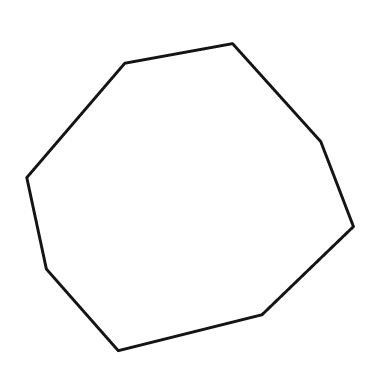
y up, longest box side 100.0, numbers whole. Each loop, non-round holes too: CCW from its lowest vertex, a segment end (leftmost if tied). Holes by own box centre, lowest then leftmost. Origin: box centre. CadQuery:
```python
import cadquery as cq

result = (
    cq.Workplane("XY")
    .moveTo(-22.0, -47.0)
    .lineTo(22.0, -36.0)
    .lineTo(50.0, -9.0)
    .lineTo(40.0, 17.0)
    .lineTo(13.0, 47.0)
    .lineTo(-20.0, 41.0)
    .lineTo(-50.0, 6.0)
    .lineTo(-44.0, -22.0)
    .close()
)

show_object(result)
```